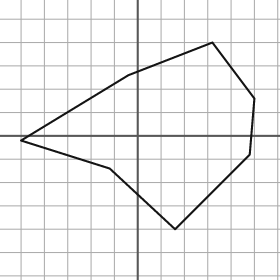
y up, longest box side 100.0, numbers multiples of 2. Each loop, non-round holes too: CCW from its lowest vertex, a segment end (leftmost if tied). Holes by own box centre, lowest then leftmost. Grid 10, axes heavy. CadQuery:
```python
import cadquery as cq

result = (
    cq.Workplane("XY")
    .moveTo(16.0, -40.0)
    .lineTo(48.0, -8.0)
    .lineTo(50.0, 16.0)
    .lineTo(32.0, 40.0)
    .lineTo(-4.0, 26.0)
    .lineTo(-50.0, -2.0)
    .lineTo(-12.0, -14.0)
    .close()
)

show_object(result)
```